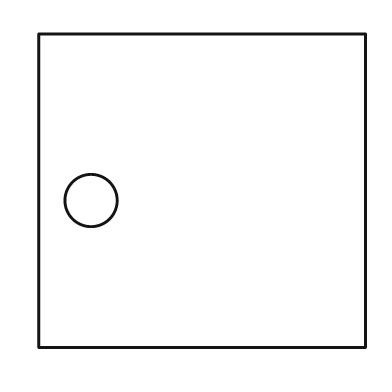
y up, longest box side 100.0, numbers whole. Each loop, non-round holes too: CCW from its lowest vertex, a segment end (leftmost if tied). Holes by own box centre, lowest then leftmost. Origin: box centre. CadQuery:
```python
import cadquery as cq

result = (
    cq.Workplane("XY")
    .moveTo(-50.0, -48.0)
    .lineTo(50.0, -48.0)
    .lineTo(50.0, 48.0)
    .lineTo(-50.0, 48.0)
    .close()
    .moveTo(-34.0, -3.0)
    .circle(8.0)
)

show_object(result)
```